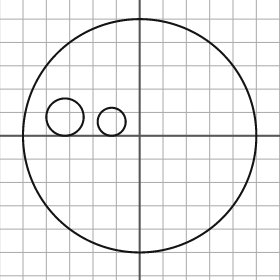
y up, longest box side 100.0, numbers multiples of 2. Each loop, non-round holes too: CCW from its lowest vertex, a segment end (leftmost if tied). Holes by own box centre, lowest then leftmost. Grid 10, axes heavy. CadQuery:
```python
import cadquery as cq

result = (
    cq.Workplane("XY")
    .moveTo(0.0, 0.0)
    .circle(50.0)
    .moveTo(-12.0, 6.0)
    .circle(6.0)
    .moveTo(-32.0, 8.0)
    .circle(8.0)
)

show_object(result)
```